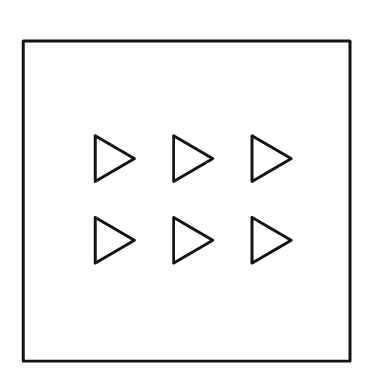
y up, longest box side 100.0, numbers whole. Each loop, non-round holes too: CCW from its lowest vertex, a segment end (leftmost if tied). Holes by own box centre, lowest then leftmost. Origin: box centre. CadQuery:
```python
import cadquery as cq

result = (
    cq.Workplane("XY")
    .moveTo(-50.0, -49.0)
    .lineTo(50.0, -49.0)
    .lineTo(50.0, 49.0)
    .lineTo(-50.0, 49.0)
    .close()
    .moveTo(-28.0, -19.0)
    .lineTo(-16.0, -12.0)
    .lineTo(-28.0, -5.0)
    .close()
    .moveTo(-4.0, -19.0)
    .lineTo(8.0, -12.0)
    .lineTo(-4.0, -5.0)
    .close()
    .moveTo(20.0, -19.0)
    .lineTo(32.0, -12.0)
    .lineTo(20.0, -5.0)
    .close()
    .moveTo(-28.0, 6.0)
    .lineTo(-16.0, 13.0)
    .lineTo(-28.0, 20.0)
    .close()
    .moveTo(-4.0, 6.0)
    .lineTo(8.0, 13.0)
    .lineTo(-4.0, 20.0)
    .close()
    .moveTo(20.0, 6.0)
    .lineTo(32.0, 13.0)
    .lineTo(20.0, 20.0)
    .close()
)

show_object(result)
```